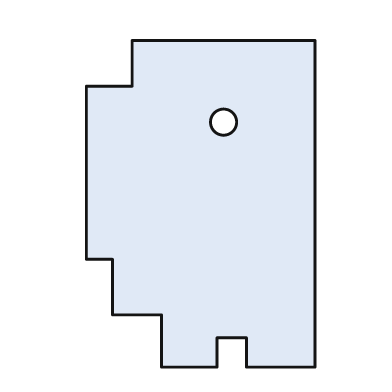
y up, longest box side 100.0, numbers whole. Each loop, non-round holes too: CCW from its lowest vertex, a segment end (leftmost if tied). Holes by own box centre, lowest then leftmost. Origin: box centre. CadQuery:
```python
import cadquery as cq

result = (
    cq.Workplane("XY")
    .moveTo(-12.0, -50.0)
    .lineTo(5.0, -50.0)
    .lineTo(5.0, -41.0)
    .lineTo(14.0, -41.0)
    .lineTo(14.0, -50.0)
    .lineTo(35.0, -50.0)
    .lineTo(35.0, 50.0)
    .lineTo(-21.0, 50.0)
    .lineTo(-21.0, 36.0)
    .lineTo(-35.0, 36.0)
    .lineTo(-35.0, -17.0)
    .lineTo(-27.0, -17.0)
    .lineTo(-27.0, -34.0)
    .lineTo(-12.0, -34.0)
    .close()
    .moveTo(7.0, 25.0)
    .circle(4.0)
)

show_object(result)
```